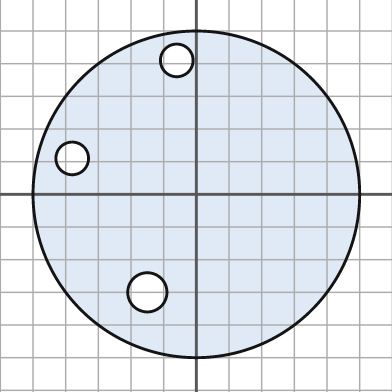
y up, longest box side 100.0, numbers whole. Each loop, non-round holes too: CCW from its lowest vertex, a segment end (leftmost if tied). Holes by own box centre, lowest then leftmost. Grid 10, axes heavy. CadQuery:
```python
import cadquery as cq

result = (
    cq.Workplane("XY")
    .moveTo(0.0, 0.0)
    .circle(50.0)
    .moveTo(-15.0, -30.0)
    .circle(6.0)
    .moveTo(-38.0, 11.0)
    .circle(5.0)
    .moveTo(-6.0, 41.0)
    .circle(5.0)
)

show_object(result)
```